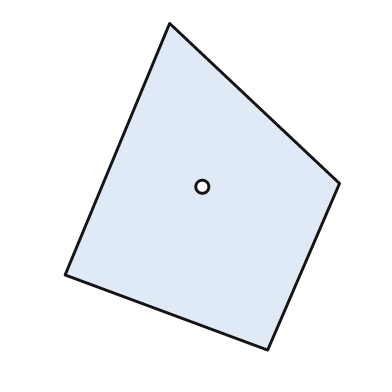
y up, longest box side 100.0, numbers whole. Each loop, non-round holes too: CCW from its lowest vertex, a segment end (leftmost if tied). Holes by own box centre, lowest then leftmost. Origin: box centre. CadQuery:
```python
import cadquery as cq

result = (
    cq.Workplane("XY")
    .moveTo(20.0, -50.0)
    .lineTo(42.0, 1.0)
    .lineTo(-10.0, 50.0)
    .lineTo(-42.0, -27.0)
    .close()
    .moveTo(0.0, 0.0)
    .circle(2.0)
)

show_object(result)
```